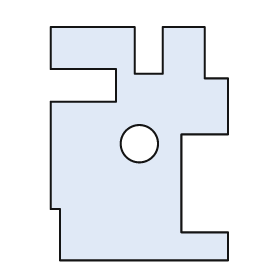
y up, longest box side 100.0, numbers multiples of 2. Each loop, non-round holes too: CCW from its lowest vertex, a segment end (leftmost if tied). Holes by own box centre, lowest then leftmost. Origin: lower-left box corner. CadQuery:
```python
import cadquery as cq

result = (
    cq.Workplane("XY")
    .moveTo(4.0, 0.0)
    .lineTo(76.0, 0.0)
    .lineTo(76.0, 12.0)
    .lineTo(56.0, 12.0)
    .lineTo(56.0, 54.0)
    .lineTo(76.0, 54.0)
    .lineTo(76.0, 78.0)
    .lineTo(66.0, 78.0)
    .lineTo(66.0, 100.0)
    .lineTo(48.0, 100.0)
    .lineTo(48.0, 80.0)
    .lineTo(36.0, 80.0)
    .lineTo(36.0, 100.0)
    .lineTo(0.0, 100.0)
    .lineTo(0.0, 82.0)
    .lineTo(28.0, 82.0)
    .lineTo(28.0, 68.0)
    .lineTo(0.0, 68.0)
    .lineTo(0.0, 22.0)
    .lineTo(4.0, 22.0)
    .close()
    .moveTo(38.0, 50.0)
    .circle(8.0)
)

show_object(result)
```